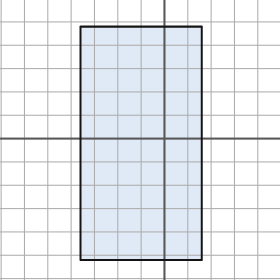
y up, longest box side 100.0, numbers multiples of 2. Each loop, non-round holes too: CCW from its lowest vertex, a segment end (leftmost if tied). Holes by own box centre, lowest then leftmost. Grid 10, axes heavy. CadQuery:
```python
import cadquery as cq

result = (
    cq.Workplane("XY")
    .moveTo(-36.0, -52.0)
    .lineTo(16.0, -52.0)
    .lineTo(16.0, 48.0)
    .lineTo(-36.0, 48.0)
    .close()
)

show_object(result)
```